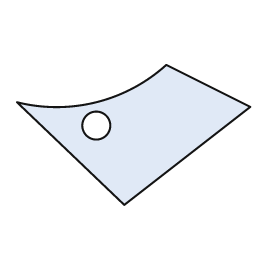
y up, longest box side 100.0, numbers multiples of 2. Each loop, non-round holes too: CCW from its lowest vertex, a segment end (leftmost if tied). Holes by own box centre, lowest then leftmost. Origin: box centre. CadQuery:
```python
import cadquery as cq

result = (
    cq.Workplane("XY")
    .moveTo(-4.0, -30.0)
    .lineTo(50.0, 12.0)
    .lineTo(14.0, 30.0)
    .threePointArc((-16.0, 14.0), (-50.0, 14.0))
    .close()
    .moveTo(-16.0, 4.0)
    .circle(6.0)
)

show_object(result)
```